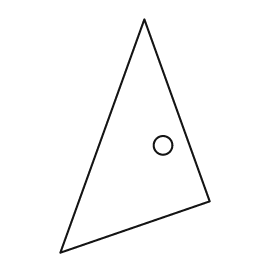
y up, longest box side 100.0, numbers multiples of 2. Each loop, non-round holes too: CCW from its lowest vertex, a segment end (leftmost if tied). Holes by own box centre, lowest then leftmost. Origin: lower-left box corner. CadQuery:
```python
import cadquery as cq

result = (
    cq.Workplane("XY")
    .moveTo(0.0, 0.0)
    .lineTo(64.0, 22.0)
    .lineTo(36.0, 100.0)
    .close()
    .moveTo(44.0, 46.0)
    .circle(4.0)
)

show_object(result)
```